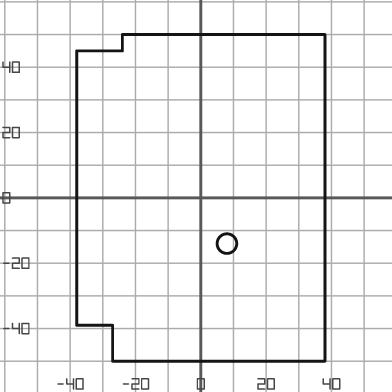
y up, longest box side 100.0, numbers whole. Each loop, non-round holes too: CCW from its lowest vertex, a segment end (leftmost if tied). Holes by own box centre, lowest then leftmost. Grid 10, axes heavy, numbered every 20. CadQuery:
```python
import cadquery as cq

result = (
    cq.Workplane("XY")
    .moveTo(-27.0, -50.0)
    .lineTo(38.0, -50.0)
    .lineTo(38.0, 50.0)
    .lineTo(-24.0, 50.0)
    .lineTo(-24.0, 45.0)
    .lineTo(-38.0, 45.0)
    .lineTo(-38.0, -39.0)
    .lineTo(-27.0, -39.0)
    .close()
    .moveTo(8.0, -14.0)
    .circle(3.0)
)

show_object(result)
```